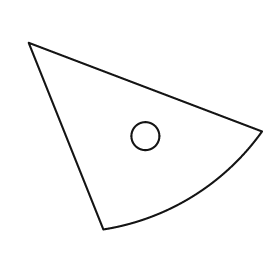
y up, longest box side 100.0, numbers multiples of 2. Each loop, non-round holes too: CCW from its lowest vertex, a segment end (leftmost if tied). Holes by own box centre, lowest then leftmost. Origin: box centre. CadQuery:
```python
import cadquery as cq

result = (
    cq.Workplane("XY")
    .moveTo(-18.0, -40.0)
    .threePointArc((20.0, -26.0), (50.0, 2.0))
    .lineTo(-50.0, 40.0)
    .close()
    .moveTo(0.0, 0.0)
    .circle(6.0)
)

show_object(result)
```